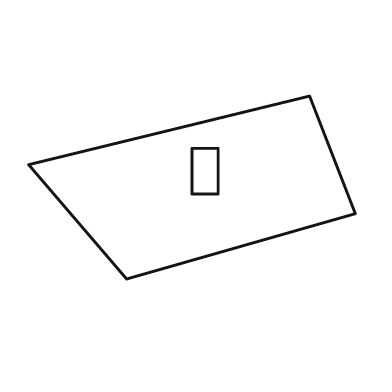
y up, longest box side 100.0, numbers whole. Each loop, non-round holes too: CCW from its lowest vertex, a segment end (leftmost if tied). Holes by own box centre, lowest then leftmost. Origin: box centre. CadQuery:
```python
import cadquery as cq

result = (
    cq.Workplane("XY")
    .moveTo(-20.0, -28.0)
    .lineTo(50.0, -8.0)
    .lineTo(36.0, 28.0)
    .lineTo(-50.0, 7.0)
    .close()
    .moveTo(0.0, -2.0)
    .lineTo(8.0, -2.0)
    .lineTo(8.0, 12.0)
    .lineTo(0.0, 12.0)
    .close()
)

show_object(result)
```